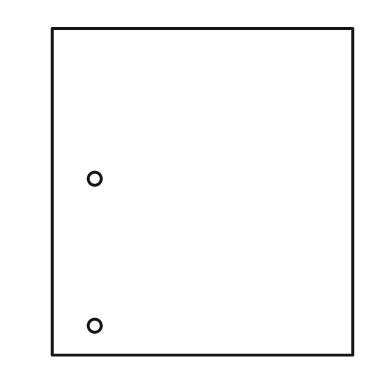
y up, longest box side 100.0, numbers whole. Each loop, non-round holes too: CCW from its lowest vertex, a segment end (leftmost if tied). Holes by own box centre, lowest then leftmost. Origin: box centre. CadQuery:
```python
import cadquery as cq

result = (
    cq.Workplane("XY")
    .moveTo(-46.0, -50.0)
    .lineTo(46.0, -50.0)
    .lineTo(46.0, 50.0)
    .lineTo(-46.0, 50.0)
    .close()
    .moveTo(-33.0, -41.0)
    .circle(2.0)
    .moveTo(-33.0, 4.0)
    .circle(2.0)
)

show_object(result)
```